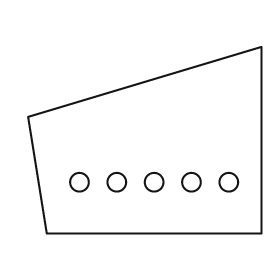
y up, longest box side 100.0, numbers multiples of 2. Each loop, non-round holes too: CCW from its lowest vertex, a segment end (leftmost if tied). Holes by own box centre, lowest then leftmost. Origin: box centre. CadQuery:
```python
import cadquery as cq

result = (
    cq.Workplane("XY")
    .moveTo(-42.0, -40.0)
    .lineTo(50.0, -40.0)
    .lineTo(50.0, 40.0)
    .lineTo(-50.0, 10.0)
    .close()
    .moveTo(-28.0, -18.0)
    .circle(4.0)
    .moveTo(-12.0, -18.0)
    .circle(4.0)
    .moveTo(4.0, -18.0)
    .circle(4.0)
    .moveTo(20.0, -18.0)
    .circle(4.0)
    .moveTo(36.0, -18.0)
    .circle(4.0)
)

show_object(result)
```